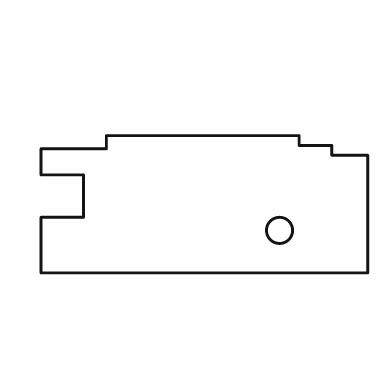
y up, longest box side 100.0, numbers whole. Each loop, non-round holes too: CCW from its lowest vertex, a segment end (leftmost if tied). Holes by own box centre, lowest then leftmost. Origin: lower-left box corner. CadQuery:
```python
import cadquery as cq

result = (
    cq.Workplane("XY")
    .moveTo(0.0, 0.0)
    .lineTo(100.0, 0.0)
    .lineTo(100.0, 36.0)
    .lineTo(89.0, 36.0)
    .lineTo(89.0, 39.0)
    .lineTo(79.0, 39.0)
    .lineTo(79.0, 42.0)
    .lineTo(20.0, 42.0)
    .lineTo(20.0, 38.0)
    .lineTo(0.0, 38.0)
    .lineTo(0.0, 30.0)
    .lineTo(13.0, 30.0)
    .lineTo(13.0, 17.0)
    .lineTo(0.0, 17.0)
    .close()
    .moveTo(73.0, 13.0)
    .circle(4.0)
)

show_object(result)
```